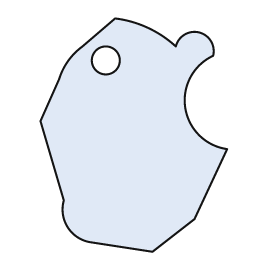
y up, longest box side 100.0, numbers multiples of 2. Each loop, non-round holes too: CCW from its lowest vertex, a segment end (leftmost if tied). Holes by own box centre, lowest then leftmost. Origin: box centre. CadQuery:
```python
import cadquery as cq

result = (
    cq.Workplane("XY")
    .moveTo(8.0, -50.0)
    .lineTo(26.0, -36.0)
    .lineTo(40.0, -6.0)
    .threePointArc((22.0, 12.0), (34.0, 34.0))
    .threePointArc((28.0, 44.0), (18.0, 38.0))
    .threePointArc((6.0, 46.0), (-8.0, 50.0))
    .lineTo(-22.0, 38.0)
    .threePointArc((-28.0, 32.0), (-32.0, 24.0))
    .lineTo(-40.0, 6.0)
    .lineTo(-30.0, -28.0)
    .threePointArc((-28.0, -40.0), (-18.0, -46.0))
    .close()
    .moveTo(-12.0, 32.0)
    .circle(6.0)
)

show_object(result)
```